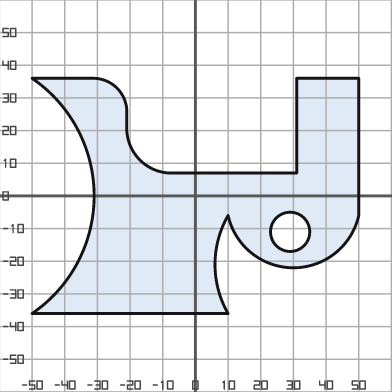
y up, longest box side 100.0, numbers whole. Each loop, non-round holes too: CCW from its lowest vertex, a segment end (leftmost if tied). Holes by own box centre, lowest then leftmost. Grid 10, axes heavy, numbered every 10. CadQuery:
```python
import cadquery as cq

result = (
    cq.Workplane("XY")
    .moveTo(-50.0, -36.0)
    .lineTo(10.0, -36.0)
    .threePointArc((6.0, -21.0), (10.0, -6.0))
    .threePointArc((30.0, -22.0), (50.0, -6.0))
    .lineTo(50.0, 36.0)
    .lineTo(31.0, 36.0)
    .lineTo(31.0, 7.0)
    .lineTo(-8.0, 7.0)
    .threePointArc((-17.0, 11.0), (-21.0, 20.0))
    .lineTo(-21.0, 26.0)
    .threePointArc((-24.0, 33.0), (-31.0, 36.0))
    .lineTo(-50.0, 36.0)
    .threePointArc((-31.0, 0.0), (-50.0, -36.0))
    .close()
    .moveTo(29.0, -11.0)
    .circle(6.0)
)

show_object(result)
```